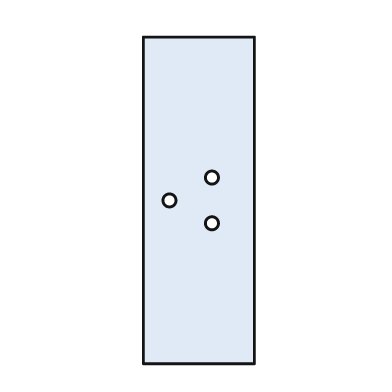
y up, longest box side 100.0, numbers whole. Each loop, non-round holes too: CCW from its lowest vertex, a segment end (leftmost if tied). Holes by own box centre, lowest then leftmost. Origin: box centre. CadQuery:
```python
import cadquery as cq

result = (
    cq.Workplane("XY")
    .moveTo(-17.0, -50.0)
    .lineTo(17.0, -50.0)
    .lineTo(17.0, 50.0)
    .lineTo(-17.0, 50.0)
    .close()
    .moveTo(4.0, -7.0)
    .circle(2.0)
    .moveTo(-9.0, 0.0)
    .circle(2.0)
    .moveTo(4.0, 7.0)
    .circle(2.0)
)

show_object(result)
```